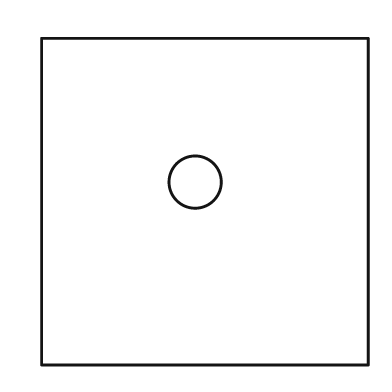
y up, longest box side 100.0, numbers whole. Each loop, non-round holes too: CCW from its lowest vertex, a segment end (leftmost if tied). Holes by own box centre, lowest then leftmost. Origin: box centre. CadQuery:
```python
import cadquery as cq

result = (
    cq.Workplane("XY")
    .moveTo(-50.0, -50.0)
    .lineTo(50.0, -50.0)
    .lineTo(50.0, 50.0)
    .lineTo(-50.0, 50.0)
    .close()
    .moveTo(-3.0, 6.0)
    .circle(8.0)
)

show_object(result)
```